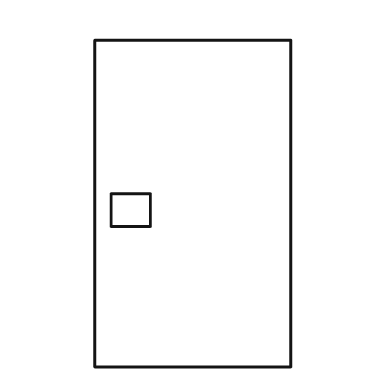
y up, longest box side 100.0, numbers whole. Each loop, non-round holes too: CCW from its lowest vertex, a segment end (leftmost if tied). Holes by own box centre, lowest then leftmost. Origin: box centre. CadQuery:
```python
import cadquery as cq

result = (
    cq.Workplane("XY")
    .moveTo(-30.0, -50.0)
    .lineTo(30.0, -50.0)
    .lineTo(30.0, 50.0)
    .lineTo(-30.0, 50.0)
    .close()
    .moveTo(-25.0, -7.0)
    .lineTo(-13.0, -7.0)
    .lineTo(-13.0, 3.0)
    .lineTo(-25.0, 3.0)
    .close()
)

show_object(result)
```